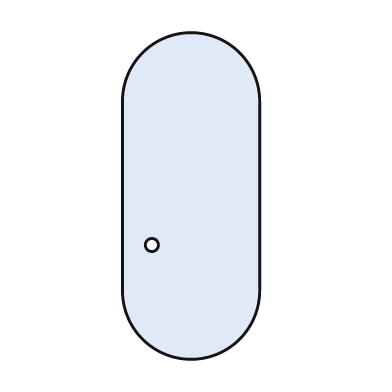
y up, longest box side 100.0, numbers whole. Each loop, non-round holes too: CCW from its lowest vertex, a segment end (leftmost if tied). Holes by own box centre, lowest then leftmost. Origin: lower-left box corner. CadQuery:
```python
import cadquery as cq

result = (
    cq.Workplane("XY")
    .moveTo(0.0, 21.0)
    .threePointArc((21.0, 0.0), (42.0, 21.0))
    .lineTo(42.0, 79.0)
    .threePointArc((21.0, 100.0), (0.0, 79.0))
    .close()
    .moveTo(9.0, 35.0)
    .circle(2.0)
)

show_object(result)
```